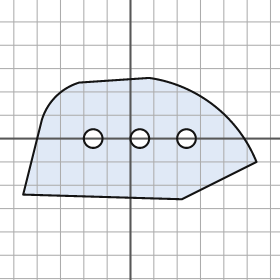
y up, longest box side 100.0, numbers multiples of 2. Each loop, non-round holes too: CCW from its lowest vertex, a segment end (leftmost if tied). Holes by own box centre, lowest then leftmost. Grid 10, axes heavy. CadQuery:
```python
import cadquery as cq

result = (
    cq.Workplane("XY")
    .moveTo(22.0, -26.0)
    .lineTo(54.0, -10.0)
    .threePointArc((36.0, 14.0), (8.0, 26.0))
    .lineTo(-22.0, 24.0)
    .threePointArc((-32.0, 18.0), (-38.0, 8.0))
    .lineTo(-46.0, -24.0)
    .close()
    .moveTo(-16.0, 0.0)
    .circle(4.0)
    .moveTo(4.0, 0.0)
    .circle(4.0)
    .moveTo(24.0, 0.0)
    .circle(4.0)
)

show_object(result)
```